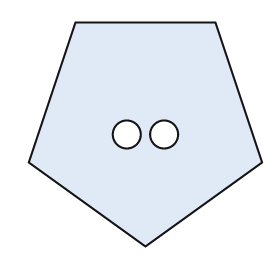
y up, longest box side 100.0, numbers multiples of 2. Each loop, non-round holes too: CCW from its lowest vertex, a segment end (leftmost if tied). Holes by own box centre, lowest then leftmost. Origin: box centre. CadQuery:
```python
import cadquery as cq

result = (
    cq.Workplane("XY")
    .moveTo(0.0, -48.0)
    .lineTo(50.0, -12.0)
    .lineTo(30.0, 48.0)
    .lineTo(-30.0, 48.0)
    .lineTo(-50.0, -12.0)
    .close()
    .moveTo(-8.0, 0.0)
    .circle(6.0)
    .moveTo(8.0, 0.0)
    .circle(6.0)
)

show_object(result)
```